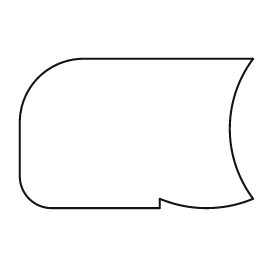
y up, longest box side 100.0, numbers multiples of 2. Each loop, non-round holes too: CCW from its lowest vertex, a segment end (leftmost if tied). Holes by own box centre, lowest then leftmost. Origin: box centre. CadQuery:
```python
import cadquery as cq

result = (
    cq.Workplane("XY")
    .moveTo(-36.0, -32.0)
    .lineTo(10.0, -32.0)
    .lineTo(10.0, -28.0)
    .threePointArc((30.0, -32.0), (50.0, -28.0))
    .threePointArc((40.0, 2.0), (50.0, 32.0))
    .lineTo(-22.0, 32.0)
    .threePointArc((-42.0, 24.0), (-50.0, 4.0))
    .lineTo(-50.0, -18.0)
    .threePointArc((-46.0, -28.0), (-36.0, -32.0))
    .close()
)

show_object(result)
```